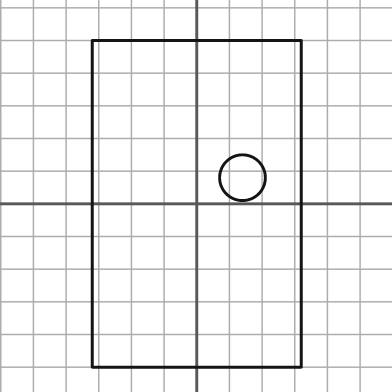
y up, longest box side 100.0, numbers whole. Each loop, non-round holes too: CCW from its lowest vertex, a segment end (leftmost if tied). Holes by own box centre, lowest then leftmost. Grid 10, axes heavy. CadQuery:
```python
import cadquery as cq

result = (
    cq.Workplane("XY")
    .moveTo(-32.0, -50.0)
    .lineTo(32.0, -50.0)
    .lineTo(32.0, 50.0)
    .lineTo(-32.0, 50.0)
    .close()
    .moveTo(14.0, 8.0)
    .circle(7.0)
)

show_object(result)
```